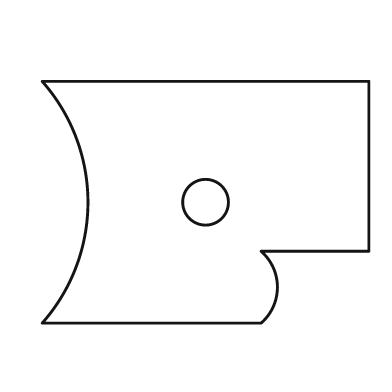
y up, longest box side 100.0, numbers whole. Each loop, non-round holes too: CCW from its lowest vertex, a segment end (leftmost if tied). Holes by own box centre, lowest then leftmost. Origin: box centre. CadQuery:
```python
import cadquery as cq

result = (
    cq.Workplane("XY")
    .moveTo(-50.0, -37.0)
    .lineTo(17.0, -37.0)
    .threePointArc((22.0, -26.0), (17.0, -15.0))
    .lineTo(50.0, -15.0)
    .lineTo(50.0, 37.0)
    .lineTo(-50.0, 37.0)
    .threePointArc((-36.0, 0.0), (-50.0, -37.0))
    .close()
    .moveTo(0.0, 0.0)
    .circle(7.0)
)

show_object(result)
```